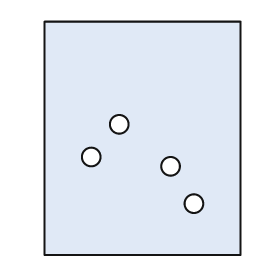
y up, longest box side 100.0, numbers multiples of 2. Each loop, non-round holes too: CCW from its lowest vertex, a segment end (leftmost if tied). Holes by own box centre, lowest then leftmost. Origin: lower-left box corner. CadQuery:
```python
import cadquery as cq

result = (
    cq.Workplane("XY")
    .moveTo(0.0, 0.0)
    .lineTo(84.0, 0.0)
    .lineTo(84.0, 100.0)
    .lineTo(0.0, 100.0)
    .close()
    .moveTo(64.0, 22.0)
    .circle(4.0)
    .moveTo(54.0, 38.0)
    .circle(4.0)
    .moveTo(20.0, 42.0)
    .circle(4.0)
    .moveTo(32.0, 56.0)
    .circle(4.0)
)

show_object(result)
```